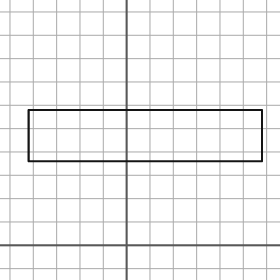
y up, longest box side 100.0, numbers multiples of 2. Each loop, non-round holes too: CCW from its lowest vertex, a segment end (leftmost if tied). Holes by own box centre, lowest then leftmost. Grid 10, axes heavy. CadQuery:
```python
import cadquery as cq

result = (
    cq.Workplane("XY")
    .moveTo(-42.0, 36.0)
    .lineTo(58.0, 36.0)
    .lineTo(58.0, 58.0)
    .lineTo(-42.0, 58.0)
    .close()
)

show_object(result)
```